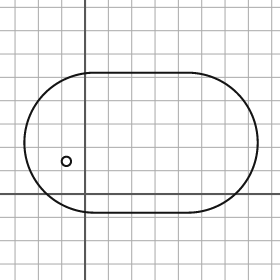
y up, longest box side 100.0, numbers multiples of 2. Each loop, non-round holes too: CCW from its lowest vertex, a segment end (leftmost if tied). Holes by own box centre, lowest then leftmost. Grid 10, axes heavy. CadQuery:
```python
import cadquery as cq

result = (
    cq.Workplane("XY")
    .moveTo(4.0, -8.0)
    .lineTo(44.0, -8.0)
    .threePointArc((74.0, 22.0), (44.0, 52.0))
    .lineTo(4.0, 52.0)
    .threePointArc((-26.0, 22.0), (4.0, -8.0))
    .close()
    .moveTo(-8.0, 14.0)
    .circle(2.0)
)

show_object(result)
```